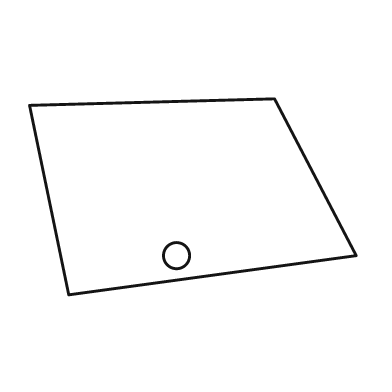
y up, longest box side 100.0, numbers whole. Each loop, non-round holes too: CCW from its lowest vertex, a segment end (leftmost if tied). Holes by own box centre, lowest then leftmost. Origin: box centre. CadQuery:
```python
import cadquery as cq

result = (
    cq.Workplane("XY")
    .moveTo(-38.0, -30.0)
    .lineTo(50.0, -18.0)
    .lineTo(25.0, 30.0)
    .lineTo(-50.0, 28.0)
    .close()
    .moveTo(-5.0, -18.0)
    .circle(4.0)
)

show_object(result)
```